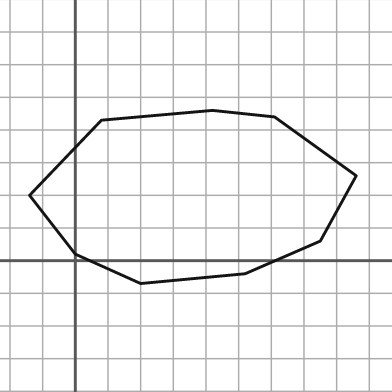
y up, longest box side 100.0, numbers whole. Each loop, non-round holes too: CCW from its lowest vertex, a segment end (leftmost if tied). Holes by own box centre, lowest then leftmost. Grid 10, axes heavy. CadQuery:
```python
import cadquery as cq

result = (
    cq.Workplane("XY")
    .moveTo(20.0, -7.0)
    .lineTo(52.0, -4.0)
    .lineTo(75.0, 6.0)
    .lineTo(86.0, 26.0)
    .lineTo(61.0, 44.0)
    .lineTo(42.0, 46.0)
    .lineTo(8.0, 43.0)
    .lineTo(-14.0, 20.0)
    .lineTo(0.0, 2.0)
    .close()
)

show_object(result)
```